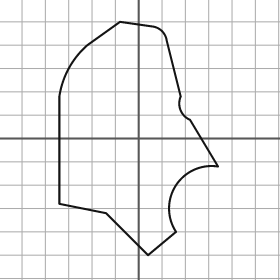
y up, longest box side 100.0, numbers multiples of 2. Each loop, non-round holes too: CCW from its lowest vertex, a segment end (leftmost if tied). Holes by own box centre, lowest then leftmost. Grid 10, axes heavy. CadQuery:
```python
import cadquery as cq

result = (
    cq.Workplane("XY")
    .moveTo(4.0, -50.0)
    .lineTo(16.0, -40.0)
    .threePointArc((16.0, -20.0), (34.0, -12.0))
    .lineTo(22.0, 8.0)
    .threePointArc((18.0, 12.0), (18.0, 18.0))
    .lineTo(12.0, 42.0)
    .threePointArc((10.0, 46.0), (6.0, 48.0))
    .lineTo(-8.0, 50.0)
    .lineTo(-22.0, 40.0)
    .threePointArc((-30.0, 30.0), (-34.0, 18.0))
    .lineTo(-34.0, -28.0)
    .lineTo(-14.0, -32.0)
    .close()
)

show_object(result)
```